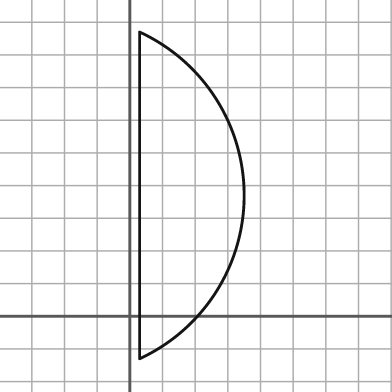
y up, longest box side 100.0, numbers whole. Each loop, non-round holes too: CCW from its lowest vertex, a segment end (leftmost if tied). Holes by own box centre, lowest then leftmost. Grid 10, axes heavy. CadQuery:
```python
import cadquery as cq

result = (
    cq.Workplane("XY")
    .moveTo(3.0, -13.0)
    .threePointArc((35.0, 37.0), (3.0, 87.0))
    .close()
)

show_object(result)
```